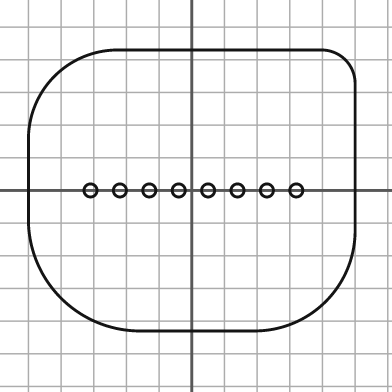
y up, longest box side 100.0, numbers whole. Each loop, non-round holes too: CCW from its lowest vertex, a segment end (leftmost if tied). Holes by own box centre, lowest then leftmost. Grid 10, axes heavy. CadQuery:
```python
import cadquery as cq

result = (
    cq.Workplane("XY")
    .moveTo(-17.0, -43.0)
    .lineTo(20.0, -43.0)
    .threePointArc((41.0, -34.0), (50.0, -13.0))
    .lineTo(50.0, 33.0)
    .threePointArc((47.0, 40.0), (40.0, 43.0))
    .lineTo(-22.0, 43.0)
    .threePointArc((-42.0, 35.0), (-50.0, 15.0))
    .lineTo(-50.0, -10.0)
    .threePointArc((-40.0, -33.0), (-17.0, -43.0))
    .close()
    .moveTo(-31.0, 0.0)
    .circle(2.0)
    .moveTo(-22.0, 0.0)
    .circle(2.0)
    .moveTo(-13.0, 0.0)
    .circle(2.0)
    .moveTo(-4.0, 0.0)
    .circle(2.0)
    .moveTo(5.0, 0.0)
    .circle(2.0)
    .moveTo(14.0, 0.0)
    .circle(2.0)
    .moveTo(23.0, 0.0)
    .circle(2.0)
    .moveTo(32.0, 0.0)
    .circle(2.0)
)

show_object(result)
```